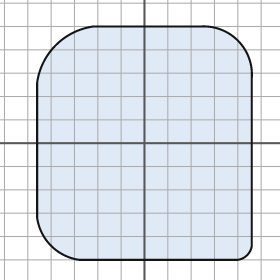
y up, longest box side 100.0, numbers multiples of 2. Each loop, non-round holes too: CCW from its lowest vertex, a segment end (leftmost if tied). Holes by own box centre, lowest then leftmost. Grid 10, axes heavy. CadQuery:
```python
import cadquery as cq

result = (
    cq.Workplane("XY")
    .moveTo(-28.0, -50.0)
    .lineTo(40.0, -50.0)
    .threePointArc((44.0, -48.0), (46.0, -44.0))
    .lineTo(46.0, 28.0)
    .threePointArc((40.0, 44.0), (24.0, 50.0))
    .lineTo(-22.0, 50.0)
    .threePointArc((-38.0, 42.0), (-46.0, 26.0))
    .lineTo(-46.0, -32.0)
    .threePointArc((-40.0, -44.0), (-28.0, -50.0))
    .close()
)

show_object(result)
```